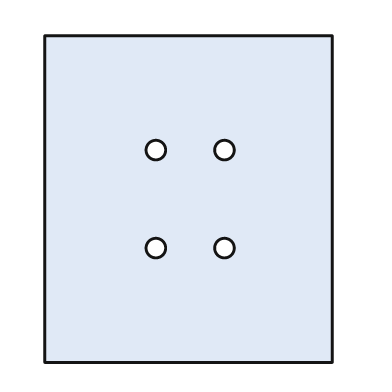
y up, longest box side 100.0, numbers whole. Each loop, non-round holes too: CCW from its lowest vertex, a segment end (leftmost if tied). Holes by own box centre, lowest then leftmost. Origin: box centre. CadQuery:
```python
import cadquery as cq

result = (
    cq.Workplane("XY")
    .moveTo(-44.0, -50.0)
    .lineTo(44.0, -50.0)
    .lineTo(44.0, 50.0)
    .lineTo(-44.0, 50.0)
    .close()
    .moveTo(-10.0, -15.0)
    .circle(3.0)
    .moveTo(11.0, -15.0)
    .circle(3.0)
    .moveTo(-10.0, 15.0)
    .circle(3.0)
    .moveTo(11.0, 15.0)
    .circle(3.0)
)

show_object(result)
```